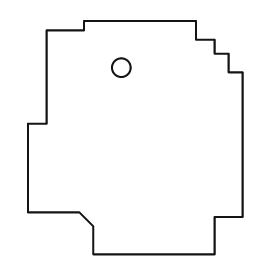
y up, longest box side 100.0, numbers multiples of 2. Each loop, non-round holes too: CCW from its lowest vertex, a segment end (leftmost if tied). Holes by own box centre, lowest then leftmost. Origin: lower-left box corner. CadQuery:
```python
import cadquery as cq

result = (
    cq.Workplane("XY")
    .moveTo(28.0, 0.0)
    .lineTo(80.0, 0.0)
    .lineTo(80.0, 16.0)
    .lineTo(92.0, 16.0)
    .lineTo(92.0, 78.0)
    .lineTo(86.0, 78.0)
    .lineTo(86.0, 86.0)
    .lineTo(80.0, 86.0)
    .lineTo(80.0, 92.0)
    .lineTo(72.0, 92.0)
    .lineTo(72.0, 100.0)
    .lineTo(24.0, 100.0)
    .lineTo(24.0, 96.0)
    .lineTo(8.0, 96.0)
    .lineTo(8.0, 56.0)
    .lineTo(0.0, 56.0)
    .lineTo(0.0, 18.0)
    .lineTo(22.0, 18.0)
    .lineTo(28.0, 12.0)
    .close()
    .moveTo(40.0, 80.0)
    .circle(4.0)
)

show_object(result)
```